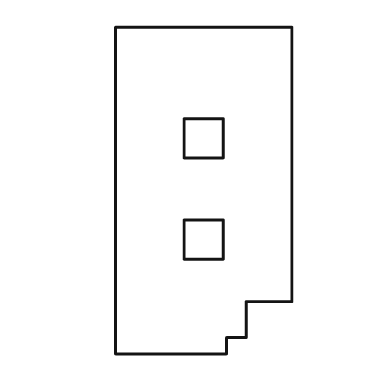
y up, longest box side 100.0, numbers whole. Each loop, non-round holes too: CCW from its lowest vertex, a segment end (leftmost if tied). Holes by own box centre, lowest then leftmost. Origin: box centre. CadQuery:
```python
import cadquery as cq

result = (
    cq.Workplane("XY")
    .moveTo(-27.0, -50.0)
    .lineTo(7.0, -50.0)
    .lineTo(7.0, -45.0)
    .lineTo(13.0, -45.0)
    .lineTo(13.0, -34.0)
    .lineTo(27.0, -34.0)
    .lineTo(27.0, 50.0)
    .lineTo(-27.0, 50.0)
    .close()
    .moveTo(-6.0, -21.0)
    .lineTo(6.0, -21.0)
    .lineTo(6.0, -9.0)
    .lineTo(-6.0, -9.0)
    .close()
    .moveTo(-6.0, 10.0)
    .lineTo(6.0, 10.0)
    .lineTo(6.0, 22.0)
    .lineTo(-6.0, 22.0)
    .close()
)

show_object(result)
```